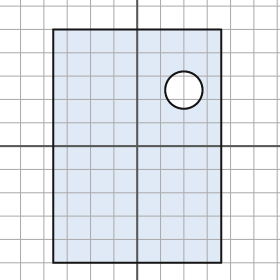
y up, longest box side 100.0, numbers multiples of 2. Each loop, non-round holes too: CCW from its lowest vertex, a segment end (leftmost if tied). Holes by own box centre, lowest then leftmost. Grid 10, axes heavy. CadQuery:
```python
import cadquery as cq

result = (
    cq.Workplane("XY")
    .moveTo(-36.0, -50.0)
    .lineTo(36.0, -50.0)
    .lineTo(36.0, 50.0)
    .lineTo(-36.0, 50.0)
    .close()
    .moveTo(20.0, 24.0)
    .circle(8.0)
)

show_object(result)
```